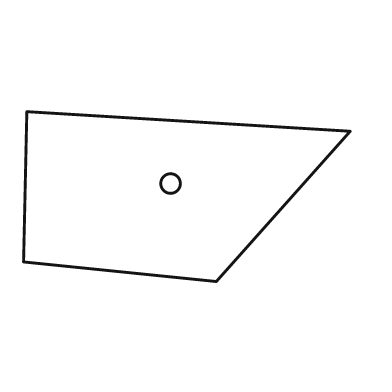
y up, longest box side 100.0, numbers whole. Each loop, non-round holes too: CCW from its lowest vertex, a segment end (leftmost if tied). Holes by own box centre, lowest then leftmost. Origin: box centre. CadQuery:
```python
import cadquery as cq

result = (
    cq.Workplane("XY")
    .moveTo(9.0, -26.0)
    .lineTo(50.0, 20.0)
    .lineTo(-49.0, 26.0)
    .lineTo(-50.0, -20.0)
    .close()
    .moveTo(-5.0, 4.0)
    .circle(3.0)
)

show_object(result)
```